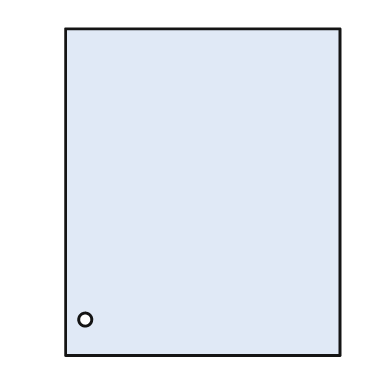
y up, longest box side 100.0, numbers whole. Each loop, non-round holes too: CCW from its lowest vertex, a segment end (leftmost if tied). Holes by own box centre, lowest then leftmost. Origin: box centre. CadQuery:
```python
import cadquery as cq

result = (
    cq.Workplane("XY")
    .moveTo(-42.0, -50.0)
    .lineTo(42.0, -50.0)
    .lineTo(42.0, 50.0)
    .lineTo(-42.0, 50.0)
    .close()
    .moveTo(-36.0, -39.0)
    .circle(2.0)
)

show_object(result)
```